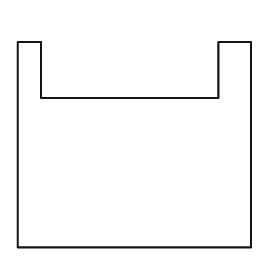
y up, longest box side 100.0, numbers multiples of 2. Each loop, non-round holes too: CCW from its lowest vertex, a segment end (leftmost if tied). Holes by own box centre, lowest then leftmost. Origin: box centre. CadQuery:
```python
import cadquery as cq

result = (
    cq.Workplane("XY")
    .moveTo(-50.0, -44.0)
    .lineTo(50.0, -44.0)
    .lineTo(50.0, 44.0)
    .lineTo(36.0, 44.0)
    .lineTo(36.0, 20.0)
    .lineTo(-40.0, 20.0)
    .lineTo(-40.0, 44.0)
    .lineTo(-50.0, 44.0)
    .close()
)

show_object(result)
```